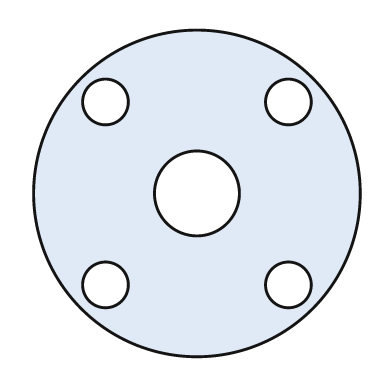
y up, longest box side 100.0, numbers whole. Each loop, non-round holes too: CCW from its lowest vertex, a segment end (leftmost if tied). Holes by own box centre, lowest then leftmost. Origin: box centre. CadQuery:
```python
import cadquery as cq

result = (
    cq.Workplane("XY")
    .moveTo(0.0, 0.0)
    .circle(50.0)
    .moveTo(-28.0, -28.0)
    .circle(7.0)
    .moveTo(28.0, -28.0)
    .circle(7.0)
    .moveTo(0.0, 0.0)
    .circle(13.0)
    .moveTo(-28.0, 28.0)
    .circle(7.0)
    .moveTo(28.0, 28.0)
    .circle(7.0)
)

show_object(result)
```